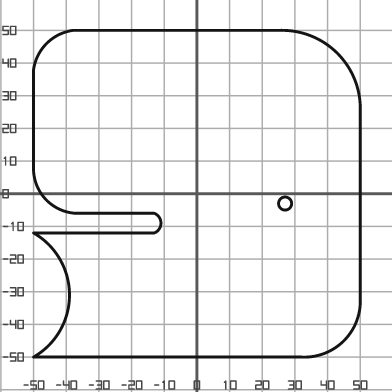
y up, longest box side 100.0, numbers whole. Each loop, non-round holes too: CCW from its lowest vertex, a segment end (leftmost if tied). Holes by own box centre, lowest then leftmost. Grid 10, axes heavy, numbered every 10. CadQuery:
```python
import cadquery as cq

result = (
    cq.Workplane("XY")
    .moveTo(-50.0, -50.0)
    .lineTo(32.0, -50.0)
    .threePointArc((45.0, -45.0), (50.0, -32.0))
    .lineTo(50.0, 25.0)
    .threePointArc((43.0, 43.0), (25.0, 50.0))
    .lineTo(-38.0, 50.0)
    .threePointArc((-46.0, 46.0), (-50.0, 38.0))
    .lineTo(-50.0, 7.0)
    .threePointArc((-46.0, -2.0), (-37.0, -6.0))
    .lineTo(-13.0, -6.0)
    .threePointArc((-11.0, -9.0), (-13.0, -12.0))
    .lineTo(-50.0, -12.0)
    .threePointArc((-39.0, -31.0), (-50.0, -50.0))
    .close()
    .moveTo(27.0, -3.0)
    .circle(2.0)
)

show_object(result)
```